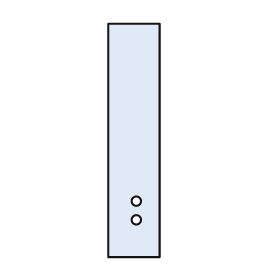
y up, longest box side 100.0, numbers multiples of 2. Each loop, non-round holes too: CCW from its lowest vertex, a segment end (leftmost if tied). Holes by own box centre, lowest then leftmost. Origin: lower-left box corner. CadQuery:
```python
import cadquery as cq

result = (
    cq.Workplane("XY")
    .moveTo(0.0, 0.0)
    .lineTo(22.0, 0.0)
    .lineTo(22.0, 100.0)
    .lineTo(0.0, 100.0)
    .close()
    .moveTo(12.0, 16.0)
    .circle(2.0)
    .moveTo(12.0, 24.0)
    .circle(2.0)
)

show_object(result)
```